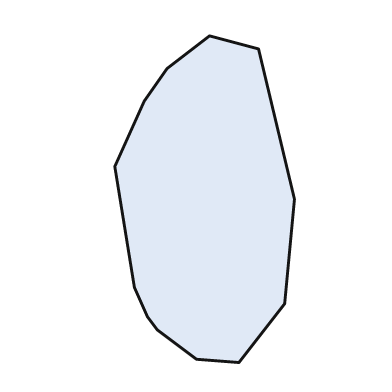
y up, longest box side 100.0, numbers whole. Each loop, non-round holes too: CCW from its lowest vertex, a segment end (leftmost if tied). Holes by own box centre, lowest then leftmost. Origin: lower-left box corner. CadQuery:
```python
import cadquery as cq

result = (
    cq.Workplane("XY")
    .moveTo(38.0, 0.0)
    .lineTo(52.0, 18.0)
    .lineTo(55.0, 50.0)
    .lineTo(44.0, 96.0)
    .lineTo(29.0, 100.0)
    .lineTo(16.0, 90.0)
    .lineTo(9.0, 80.0)
    .lineTo(0.0, 60.0)
    .lineTo(6.0, 23.0)
    .lineTo(10.0, 14.0)
    .lineTo(13.0, 10.0)
    .lineTo(25.0, 1.0)
    .close()
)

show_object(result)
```